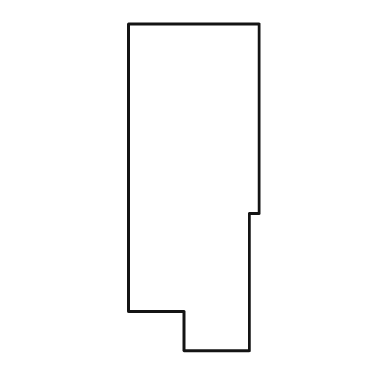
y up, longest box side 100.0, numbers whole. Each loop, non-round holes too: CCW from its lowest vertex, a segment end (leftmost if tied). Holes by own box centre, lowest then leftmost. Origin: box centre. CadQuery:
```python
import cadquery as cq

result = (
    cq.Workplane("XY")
    .moveTo(-3.0, -50.0)
    .lineTo(17.0, -50.0)
    .lineTo(17.0, -8.0)
    .lineTo(20.0, -8.0)
    .lineTo(20.0, 50.0)
    .lineTo(-20.0, 50.0)
    .lineTo(-20.0, -38.0)
    .lineTo(-3.0, -38.0)
    .close()
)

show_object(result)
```